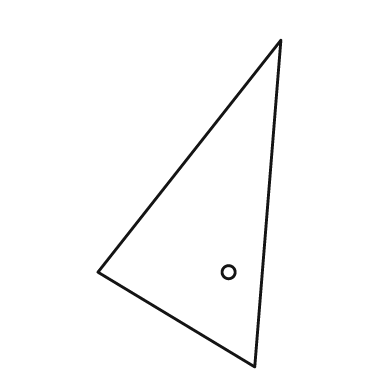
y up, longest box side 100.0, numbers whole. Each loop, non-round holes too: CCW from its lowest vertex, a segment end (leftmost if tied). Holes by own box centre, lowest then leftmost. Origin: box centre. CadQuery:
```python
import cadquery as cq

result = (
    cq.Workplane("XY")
    .moveTo(20.0, -50.0)
    .lineTo(28.0, 50.0)
    .lineTo(-28.0, -21.0)
    .close()
    .moveTo(12.0, -21.0)
    .circle(2.0)
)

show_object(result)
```